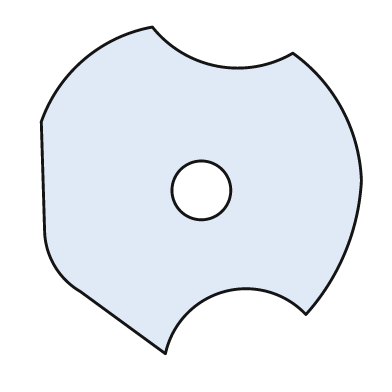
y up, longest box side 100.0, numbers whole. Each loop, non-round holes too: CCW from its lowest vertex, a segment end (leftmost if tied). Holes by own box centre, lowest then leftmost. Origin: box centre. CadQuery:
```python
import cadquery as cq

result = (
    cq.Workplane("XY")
    .moveTo(-11.0, -50.0)
    .threePointArc((7.0, -31.0), (32.0, -38.0))
    .threePointArc((44.0, -19.0), (49.0, 3.0))
    .threePointArc((43.0, 25.0), (28.0, 42.0))
    .threePointArc((5.0, 38.0), (-15.0, 50.0))
    .threePointArc((-36.0, 40.0), (-49.0, 21.0))
    .lineTo(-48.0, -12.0)
    .threePointArc((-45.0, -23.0), (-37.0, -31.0))
    .close()
    .moveTo(0.0, 0.0)
    .circle(9.0)
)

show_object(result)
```